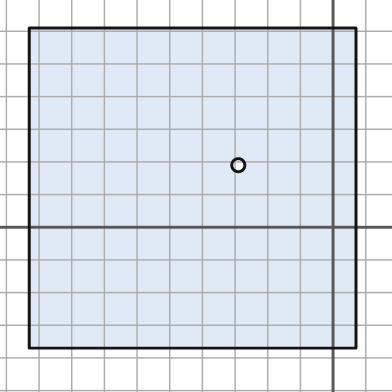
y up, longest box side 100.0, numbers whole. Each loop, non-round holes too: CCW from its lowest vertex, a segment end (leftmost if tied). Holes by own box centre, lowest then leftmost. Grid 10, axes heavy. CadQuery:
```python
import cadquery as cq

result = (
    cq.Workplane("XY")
    .moveTo(-93.0, -37.0)
    .lineTo(7.0, -37.0)
    .lineTo(7.0, 61.0)
    .lineTo(-93.0, 61.0)
    .close()
    .moveTo(-29.0, 19.0)
    .circle(2.0)
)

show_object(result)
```